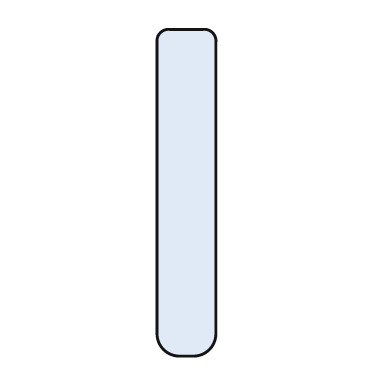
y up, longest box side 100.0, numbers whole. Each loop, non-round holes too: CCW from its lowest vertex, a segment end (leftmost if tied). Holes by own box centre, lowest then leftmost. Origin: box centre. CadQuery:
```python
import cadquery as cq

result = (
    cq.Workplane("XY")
    .moveTo(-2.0, -50.0)
    .lineTo(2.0, -50.0)
    .threePointArc((7.0, -48.0), (9.0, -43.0))
    .lineTo(9.0, 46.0)
    .threePointArc((8.0, 49.0), (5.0, 50.0))
    .lineTo(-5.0, 50.0)
    .threePointArc((-8.0, 49.0), (-9.0, 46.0))
    .lineTo(-9.0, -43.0)
    .threePointArc((-7.0, -48.0), (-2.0, -50.0))
    .close()
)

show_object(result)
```